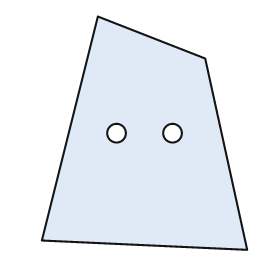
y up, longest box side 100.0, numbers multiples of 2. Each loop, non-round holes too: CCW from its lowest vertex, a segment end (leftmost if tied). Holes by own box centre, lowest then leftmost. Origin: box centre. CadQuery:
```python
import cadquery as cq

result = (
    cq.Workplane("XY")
    .moveTo(44.0, -50.0)
    .lineTo(26.0, 32.0)
    .lineTo(-20.0, 50.0)
    .lineTo(-44.0, -46.0)
    .close()
    .moveTo(-12.0, 0.0)
    .circle(4.0)
    .moveTo(12.0, 0.0)
    .circle(4.0)
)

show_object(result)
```